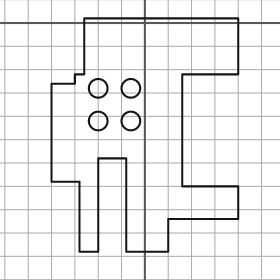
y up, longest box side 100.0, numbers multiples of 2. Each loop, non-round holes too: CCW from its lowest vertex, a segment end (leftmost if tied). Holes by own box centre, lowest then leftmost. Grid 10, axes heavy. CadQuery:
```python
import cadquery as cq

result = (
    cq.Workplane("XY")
    .moveTo(-28.0, -98.0)
    .lineTo(-20.0, -98.0)
    .lineTo(-20.0, -58.0)
    .lineTo(-8.0, -58.0)
    .lineTo(-8.0, -98.0)
    .lineTo(10.0, -98.0)
    .lineTo(10.0, -84.0)
    .lineTo(40.0, -84.0)
    .lineTo(40.0, -70.0)
    .lineTo(16.0, -70.0)
    .lineTo(16.0, -22.0)
    .lineTo(40.0, -22.0)
    .lineTo(40.0, 2.0)
    .lineTo(-26.0, 2.0)
    .lineTo(-26.0, -22.0)
    .lineTo(-30.0, -22.0)
    .lineTo(-30.0, -26.0)
    .lineTo(-40.0, -26.0)
    .lineTo(-40.0, -68.0)
    .lineTo(-28.0, -68.0)
    .close()
    .moveTo(-20.0, -42.0)
    .circle(4.0)
    .moveTo(-6.0, -42.0)
    .circle(4.0)
    .moveTo(-20.0, -28.0)
    .circle(4.0)
    .moveTo(-6.0, -28.0)
    .circle(4.0)
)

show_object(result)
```